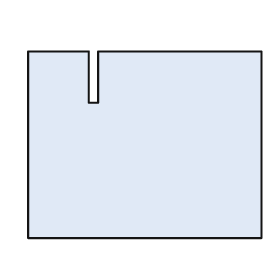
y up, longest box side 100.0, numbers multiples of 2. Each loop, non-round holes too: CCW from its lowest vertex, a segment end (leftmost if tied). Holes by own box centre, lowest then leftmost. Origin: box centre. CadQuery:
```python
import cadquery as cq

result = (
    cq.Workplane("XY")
    .moveTo(-50.0, -40.0)
    .lineTo(50.0, -40.0)
    .lineTo(50.0, 40.0)
    .lineTo(-20.0, 40.0)
    .lineTo(-20.0, 18.0)
    .lineTo(-24.0, 18.0)
    .lineTo(-24.0, 40.0)
    .lineTo(-50.0, 40.0)
    .close()
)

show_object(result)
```